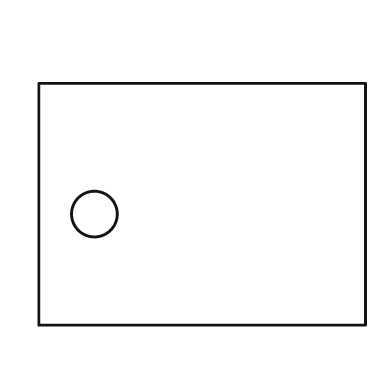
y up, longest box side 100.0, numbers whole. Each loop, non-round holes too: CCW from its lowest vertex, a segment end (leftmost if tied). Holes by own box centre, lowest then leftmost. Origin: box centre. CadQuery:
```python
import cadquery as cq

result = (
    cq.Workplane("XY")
    .moveTo(-50.0, -37.0)
    .lineTo(50.0, -37.0)
    .lineTo(50.0, 37.0)
    .lineTo(-50.0, 37.0)
    .close()
    .moveTo(-33.0, -3.0)
    .circle(7.0)
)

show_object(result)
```